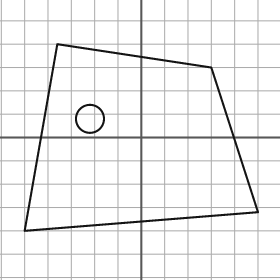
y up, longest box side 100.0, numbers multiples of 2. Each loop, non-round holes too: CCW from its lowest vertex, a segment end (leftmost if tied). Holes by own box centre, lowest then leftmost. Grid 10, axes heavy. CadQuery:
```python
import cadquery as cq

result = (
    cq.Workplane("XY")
    .moveTo(-50.0, -40.0)
    .lineTo(50.0, -32.0)
    .lineTo(30.0, 30.0)
    .lineTo(-36.0, 40.0)
    .close()
    .moveTo(-22.0, 8.0)
    .circle(6.0)
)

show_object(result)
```